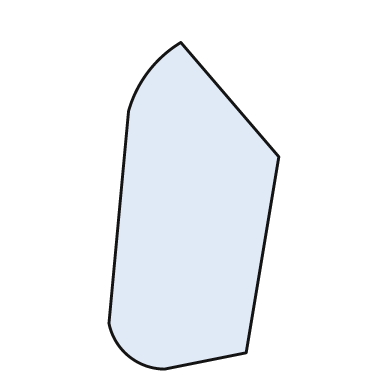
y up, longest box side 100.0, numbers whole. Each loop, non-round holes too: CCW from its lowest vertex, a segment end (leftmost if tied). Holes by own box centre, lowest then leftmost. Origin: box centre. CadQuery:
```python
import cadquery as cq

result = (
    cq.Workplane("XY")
    .moveTo(-9.0, -50.0)
    .lineTo(16.0, -45.0)
    .lineTo(26.0, 15.0)
    .lineTo(-4.0, 50.0)
    .threePointArc((-14.0, 41.0), (-20.0, 29.0))
    .lineTo(-26.0, -36.0)
    .threePointArc((-20.0, -46.0), (-9.0, -50.0))
    .close()
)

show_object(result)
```